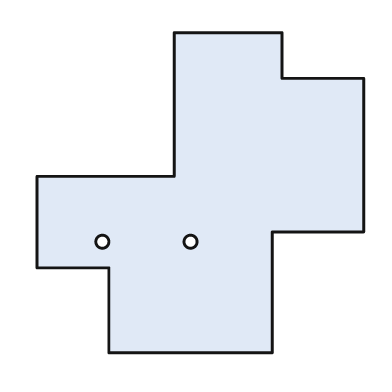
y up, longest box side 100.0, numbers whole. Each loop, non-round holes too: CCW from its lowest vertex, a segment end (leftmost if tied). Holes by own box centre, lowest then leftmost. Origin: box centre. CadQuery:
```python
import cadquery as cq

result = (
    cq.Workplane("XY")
    .moveTo(-28.0, -49.0)
    .lineTo(22.0, -49.0)
    .lineTo(22.0, -12.0)
    .lineTo(50.0, -12.0)
    .lineTo(50.0, 35.0)
    .lineTo(25.0, 35.0)
    .lineTo(25.0, 49.0)
    .lineTo(-8.0, 49.0)
    .lineTo(-8.0, 5.0)
    .lineTo(-50.0, 5.0)
    .lineTo(-50.0, -23.0)
    .lineTo(-28.0, -23.0)
    .close()
    .moveTo(-30.0, -15.0)
    .circle(2.0)
    .moveTo(-3.0, -15.0)
    .circle(2.0)
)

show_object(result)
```